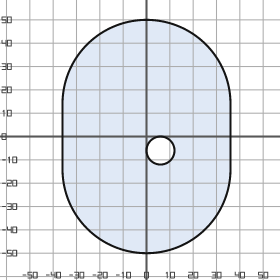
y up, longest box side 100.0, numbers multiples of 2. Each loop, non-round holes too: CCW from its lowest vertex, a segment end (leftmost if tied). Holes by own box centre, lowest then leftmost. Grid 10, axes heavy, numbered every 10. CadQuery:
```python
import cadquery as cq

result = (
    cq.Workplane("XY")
    .moveTo(-36.0, -14.0)
    .threePointArc((0.0, -50.0), (36.0, -14.0))
    .lineTo(36.0, 14.0)
    .threePointArc((0.0, 50.0), (-36.0, 14.0))
    .close()
    .moveTo(6.0, -6.0)
    .circle(6.0)
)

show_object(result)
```